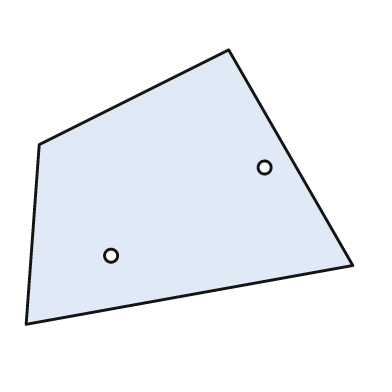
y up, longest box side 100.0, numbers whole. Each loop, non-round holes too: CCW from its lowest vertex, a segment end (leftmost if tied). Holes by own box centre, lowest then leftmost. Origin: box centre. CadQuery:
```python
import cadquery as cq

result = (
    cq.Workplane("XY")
    .moveTo(-50.0, -42.0)
    .lineTo(50.0, -24.0)
    .lineTo(12.0, 42.0)
    .lineTo(-46.0, 13.0)
    .close()
    .moveTo(-24.0, -21.0)
    .circle(2.0)
    .moveTo(23.0, 6.0)
    .circle(2.0)
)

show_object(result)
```